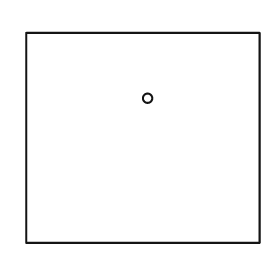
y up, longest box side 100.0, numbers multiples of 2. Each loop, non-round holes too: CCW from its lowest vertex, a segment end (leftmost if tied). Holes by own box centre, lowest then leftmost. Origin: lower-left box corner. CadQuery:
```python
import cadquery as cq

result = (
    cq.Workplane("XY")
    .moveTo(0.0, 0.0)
    .lineTo(100.0, 0.0)
    .lineTo(100.0, 90.0)
    .lineTo(0.0, 90.0)
    .close()
    .moveTo(52.0, 62.0)
    .circle(2.0)
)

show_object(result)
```